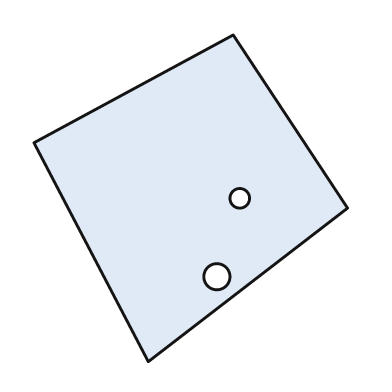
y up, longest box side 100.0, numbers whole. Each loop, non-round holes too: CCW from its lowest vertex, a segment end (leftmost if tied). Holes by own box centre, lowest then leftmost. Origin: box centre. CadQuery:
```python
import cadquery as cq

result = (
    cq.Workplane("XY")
    .moveTo(-13.0, -50.0)
    .lineTo(48.0, -3.0)
    .lineTo(13.0, 50.0)
    .lineTo(-48.0, 17.0)
    .close()
    .moveTo(8.0, -24.0)
    .circle(4.0)
    .moveTo(15.0, 0.0)
    .circle(3.0)
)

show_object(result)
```